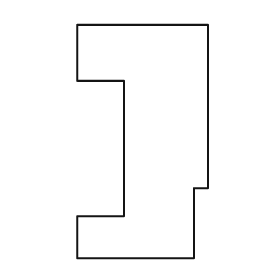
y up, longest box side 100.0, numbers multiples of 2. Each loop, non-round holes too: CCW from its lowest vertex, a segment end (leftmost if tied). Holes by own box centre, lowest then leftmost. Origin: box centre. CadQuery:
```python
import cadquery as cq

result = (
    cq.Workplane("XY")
    .moveTo(-28.0, -50.0)
    .lineTo(22.0, -50.0)
    .lineTo(22.0, -20.0)
    .lineTo(28.0, -20.0)
    .lineTo(28.0, 50.0)
    .lineTo(-28.0, 50.0)
    .lineTo(-28.0, 26.0)
    .lineTo(-8.0, 26.0)
    .lineTo(-8.0, -32.0)
    .lineTo(-28.0, -32.0)
    .close()
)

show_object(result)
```